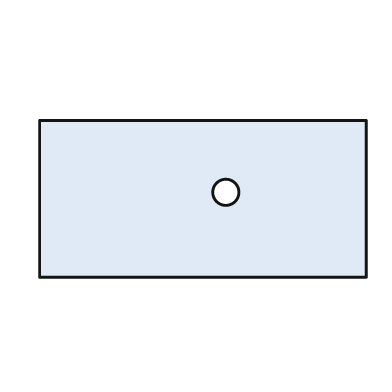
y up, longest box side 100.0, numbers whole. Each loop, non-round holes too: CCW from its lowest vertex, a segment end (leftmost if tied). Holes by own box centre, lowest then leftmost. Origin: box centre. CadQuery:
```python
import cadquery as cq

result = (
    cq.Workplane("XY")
    .moveTo(-50.0, -24.0)
    .lineTo(50.0, -24.0)
    .lineTo(50.0, 24.0)
    .lineTo(-50.0, 24.0)
    .close()
    .moveTo(7.0, 2.0)
    .circle(4.0)
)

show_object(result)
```